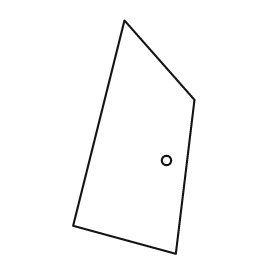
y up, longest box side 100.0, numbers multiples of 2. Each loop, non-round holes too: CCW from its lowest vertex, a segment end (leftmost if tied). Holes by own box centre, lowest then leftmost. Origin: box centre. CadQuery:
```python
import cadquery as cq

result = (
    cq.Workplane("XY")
    .moveTo(18.0, -50.0)
    .lineTo(26.0, 16.0)
    .lineTo(-4.0, 50.0)
    .lineTo(-26.0, -38.0)
    .close()
    .moveTo(14.0, -10.0)
    .circle(2.0)
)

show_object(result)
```